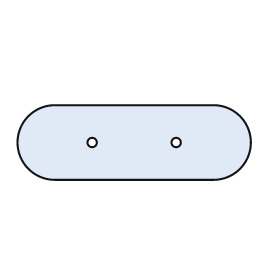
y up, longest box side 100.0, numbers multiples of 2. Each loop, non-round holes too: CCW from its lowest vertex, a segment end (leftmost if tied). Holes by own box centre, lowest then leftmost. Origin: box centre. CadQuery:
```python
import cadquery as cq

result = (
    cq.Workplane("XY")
    .moveTo(-34.0, -16.0)
    .lineTo(34.0, -16.0)
    .threePointArc((50.0, 0.0), (34.0, 16.0))
    .lineTo(-34.0, 16.0)
    .threePointArc((-50.0, 0.0), (-34.0, -16.0))
    .close()
    .moveTo(-18.0, 0.0)
    .circle(2.0)
    .moveTo(18.0, 0.0)
    .circle(2.0)
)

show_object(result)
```